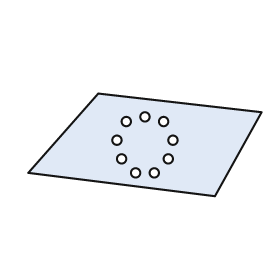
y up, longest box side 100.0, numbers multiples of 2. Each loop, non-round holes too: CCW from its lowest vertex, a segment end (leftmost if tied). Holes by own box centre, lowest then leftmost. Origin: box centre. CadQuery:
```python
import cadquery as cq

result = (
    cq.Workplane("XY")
    .moveTo(30.0, -22.0)
    .lineTo(50.0, 14.0)
    .lineTo(-20.0, 22.0)
    .lineTo(-50.0, -12.0)
    .close()
    .moveTo(-4.0, -12.0)
    .circle(2.0)
    .moveTo(4.0, -12.0)
    .circle(2.0)
    .moveTo(-10.0, -6.0)
    .circle(2.0)
    .moveTo(10.0, -6.0)
    .circle(2.0)
    .moveTo(-12.0, 2.0)
    .circle(2.0)
    .moveTo(12.0, 2.0)
    .circle(2.0)
    .moveTo(-8.0, 10.0)
    .circle(2.0)
    .moveTo(8.0, 10.0)
    .circle(2.0)
    .moveTo(0.0, 12.0)
    .circle(2.0)
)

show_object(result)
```